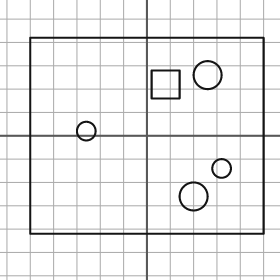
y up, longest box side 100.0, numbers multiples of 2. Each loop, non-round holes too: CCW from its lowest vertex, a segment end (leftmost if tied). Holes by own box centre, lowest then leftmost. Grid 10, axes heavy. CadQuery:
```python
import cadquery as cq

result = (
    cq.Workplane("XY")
    .moveTo(-50.0, -42.0)
    .lineTo(50.0, -42.0)
    .lineTo(50.0, 42.0)
    .lineTo(-50.0, 42.0)
    .close()
    .moveTo(20.0, -26.0)
    .circle(6.0)
    .moveTo(32.0, -14.0)
    .circle(4.0)
    .moveTo(-26.0, 2.0)
    .circle(4.0)
    .moveTo(2.0, 16.0)
    .lineTo(14.0, 16.0)
    .lineTo(14.0, 28.0)
    .lineTo(2.0, 28.0)
    .close()
    .moveTo(26.0, 26.0)
    .circle(6.0)
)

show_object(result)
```